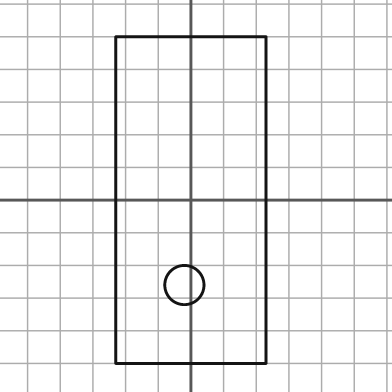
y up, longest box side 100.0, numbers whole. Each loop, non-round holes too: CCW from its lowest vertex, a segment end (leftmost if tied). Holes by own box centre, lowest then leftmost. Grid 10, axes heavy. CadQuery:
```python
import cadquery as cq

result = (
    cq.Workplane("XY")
    .moveTo(-23.0, -50.0)
    .lineTo(23.0, -50.0)
    .lineTo(23.0, 50.0)
    .lineTo(-23.0, 50.0)
    .close()
    .moveTo(-2.0, -26.0)
    .circle(6.0)
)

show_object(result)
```